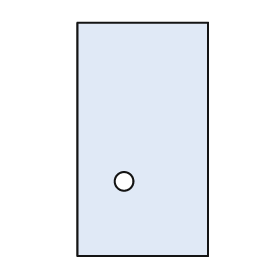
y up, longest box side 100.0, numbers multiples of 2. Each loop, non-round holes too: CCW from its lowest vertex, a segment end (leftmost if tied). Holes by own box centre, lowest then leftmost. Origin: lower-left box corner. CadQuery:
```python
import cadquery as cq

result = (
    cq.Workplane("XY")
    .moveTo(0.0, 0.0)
    .lineTo(56.0, 0.0)
    .lineTo(56.0, 100.0)
    .lineTo(0.0, 100.0)
    .close()
    .moveTo(20.0, 32.0)
    .circle(4.0)
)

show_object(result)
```